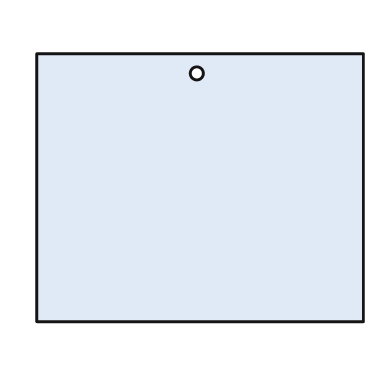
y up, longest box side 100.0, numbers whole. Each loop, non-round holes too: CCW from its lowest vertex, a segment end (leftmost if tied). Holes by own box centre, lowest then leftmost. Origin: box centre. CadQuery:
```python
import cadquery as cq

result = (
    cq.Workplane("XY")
    .moveTo(-50.0, -41.0)
    .lineTo(50.0, -41.0)
    .lineTo(50.0, 41.0)
    .lineTo(-50.0, 41.0)
    .close()
    .moveTo(-1.0, 35.0)
    .circle(2.0)
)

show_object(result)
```